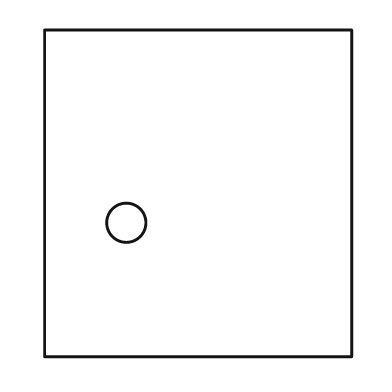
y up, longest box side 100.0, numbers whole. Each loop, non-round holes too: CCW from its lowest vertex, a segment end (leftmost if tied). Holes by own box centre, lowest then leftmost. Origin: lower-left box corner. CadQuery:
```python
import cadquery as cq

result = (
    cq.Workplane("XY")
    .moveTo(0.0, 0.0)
    .lineTo(94.0, 0.0)
    .lineTo(94.0, 100.0)
    .lineTo(0.0, 100.0)
    .close()
    .moveTo(25.0, 41.0)
    .circle(6.0)
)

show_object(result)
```